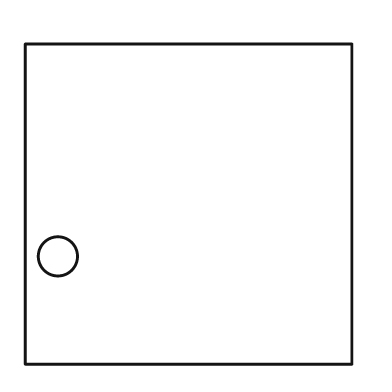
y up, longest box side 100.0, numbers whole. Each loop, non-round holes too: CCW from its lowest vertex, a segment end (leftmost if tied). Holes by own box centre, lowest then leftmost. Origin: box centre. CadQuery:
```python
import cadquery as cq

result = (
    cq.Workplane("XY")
    .moveTo(-50.0, -49.0)
    .lineTo(50.0, -49.0)
    .lineTo(50.0, 49.0)
    .lineTo(-50.0, 49.0)
    .close()
    .moveTo(-40.0, -16.0)
    .circle(6.0)
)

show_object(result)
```